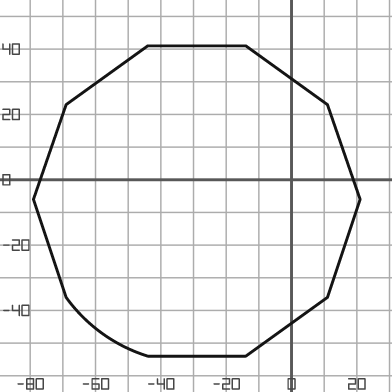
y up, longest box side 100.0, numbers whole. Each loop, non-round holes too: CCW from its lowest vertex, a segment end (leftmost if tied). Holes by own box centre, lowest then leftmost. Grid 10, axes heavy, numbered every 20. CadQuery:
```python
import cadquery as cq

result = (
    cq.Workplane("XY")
    .moveTo(-44.0, -54.0)
    .lineTo(-14.0, -54.0)
    .lineTo(11.0, -36.0)
    .lineTo(21.0, -6.0)
    .lineTo(11.0, 23.0)
    .lineTo(-14.0, 41.0)
    .lineTo(-44.0, 41.0)
    .lineTo(-69.0, 23.0)
    .lineTo(-79.0, -6.0)
    .lineTo(-69.0, -36.0)
    .threePointArc((-58.0, -47.0), (-44.0, -54.0))
    .close()
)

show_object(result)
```